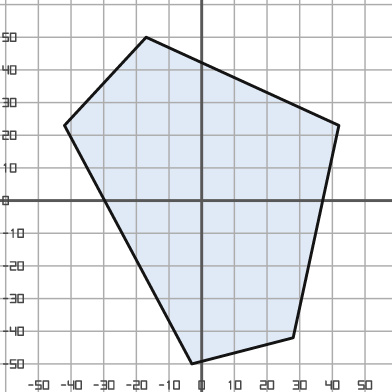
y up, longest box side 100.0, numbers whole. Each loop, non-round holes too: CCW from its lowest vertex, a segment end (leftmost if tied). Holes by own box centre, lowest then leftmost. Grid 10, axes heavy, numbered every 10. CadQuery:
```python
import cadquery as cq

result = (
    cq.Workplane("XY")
    .moveTo(-3.0, -50.0)
    .lineTo(28.0, -42.0)
    .lineTo(42.0, 23.0)
    .lineTo(-17.0, 50.0)
    .lineTo(-42.0, 23.0)
    .close()
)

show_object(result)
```